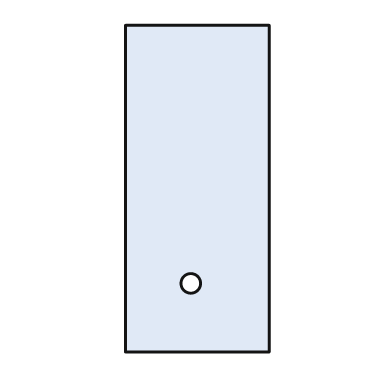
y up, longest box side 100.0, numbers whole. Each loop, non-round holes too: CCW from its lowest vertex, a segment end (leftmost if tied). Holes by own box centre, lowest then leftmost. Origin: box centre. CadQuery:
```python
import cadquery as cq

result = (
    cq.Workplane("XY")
    .moveTo(-22.0, -50.0)
    .lineTo(22.0, -50.0)
    .lineTo(22.0, 50.0)
    .lineTo(-22.0, 50.0)
    .close()
    .moveTo(-2.0, -29.0)
    .circle(3.0)
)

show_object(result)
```